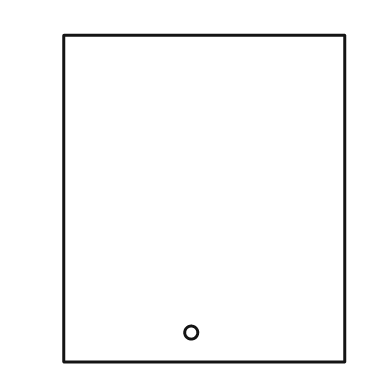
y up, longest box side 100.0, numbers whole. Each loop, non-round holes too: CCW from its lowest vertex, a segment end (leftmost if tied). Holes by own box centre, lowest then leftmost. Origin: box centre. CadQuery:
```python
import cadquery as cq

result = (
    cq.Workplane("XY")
    .moveTo(-43.0, -50.0)
    .lineTo(43.0, -50.0)
    .lineTo(43.0, 50.0)
    .lineTo(-43.0, 50.0)
    .close()
    .moveTo(-4.0, -41.0)
    .circle(2.0)
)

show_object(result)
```